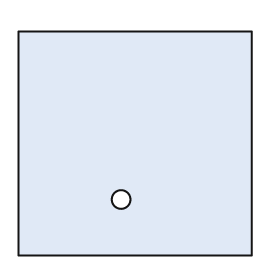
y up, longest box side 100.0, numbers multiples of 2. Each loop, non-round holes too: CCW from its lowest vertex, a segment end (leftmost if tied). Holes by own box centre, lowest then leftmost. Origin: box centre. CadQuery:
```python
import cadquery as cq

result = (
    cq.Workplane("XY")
    .moveTo(-50.0, -48.0)
    .lineTo(50.0, -48.0)
    .lineTo(50.0, 48.0)
    .lineTo(-50.0, 48.0)
    .close()
    .moveTo(-6.0, -24.0)
    .circle(4.0)
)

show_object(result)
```